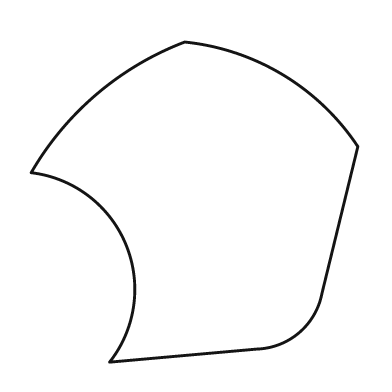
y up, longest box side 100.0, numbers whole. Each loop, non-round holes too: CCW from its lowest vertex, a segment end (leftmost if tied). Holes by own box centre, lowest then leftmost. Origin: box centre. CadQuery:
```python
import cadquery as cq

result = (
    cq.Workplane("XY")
    .moveTo(-26.0, -49.0)
    .lineTo(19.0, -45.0)
    .threePointArc((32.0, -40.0), (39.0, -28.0))
    .lineTo(50.0, 17.0)
    .threePointArc((27.0, 39.0), (-3.0, 49.0))
    .threePointArc((-30.0, 33.0), (-50.0, 9.0))
    .threePointArc((-21.0, -13.0), (-26.0, -49.0))
    .close()
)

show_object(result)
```